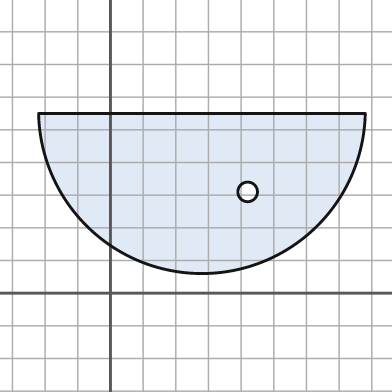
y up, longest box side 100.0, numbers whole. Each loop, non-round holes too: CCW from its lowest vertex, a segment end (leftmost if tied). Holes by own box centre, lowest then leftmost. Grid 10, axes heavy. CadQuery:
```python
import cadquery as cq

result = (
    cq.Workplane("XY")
    .moveTo(-22.0, 55.0)
    .threePointArc((28.0, 6.0), (78.0, 55.0))
    .close()
    .moveTo(42.0, 31.0)
    .circle(3.0)
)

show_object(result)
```